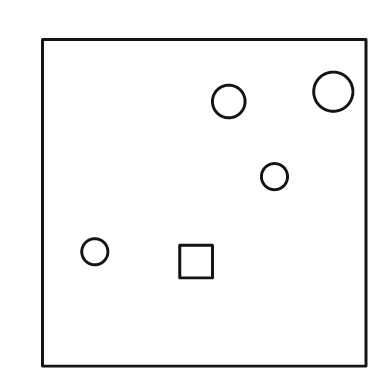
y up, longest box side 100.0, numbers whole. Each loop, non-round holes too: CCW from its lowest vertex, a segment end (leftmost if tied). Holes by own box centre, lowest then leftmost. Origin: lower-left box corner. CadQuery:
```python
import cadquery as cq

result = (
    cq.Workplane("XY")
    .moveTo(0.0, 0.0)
    .lineTo(99.0, 0.0)
    .lineTo(99.0, 100.0)
    .lineTo(0.0, 100.0)
    .close()
    .moveTo(42.0, 27.0)
    .lineTo(52.0, 27.0)
    .lineTo(52.0, 37.0)
    .lineTo(42.0, 37.0)
    .close()
    .moveTo(16.0, 35.0)
    .circle(4.0)
    .moveTo(71.0, 58.0)
    .circle(4.0)
    .moveTo(57.0, 81.0)
    .circle(5.0)
    .moveTo(89.0, 84.0)
    .circle(6.0)
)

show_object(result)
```